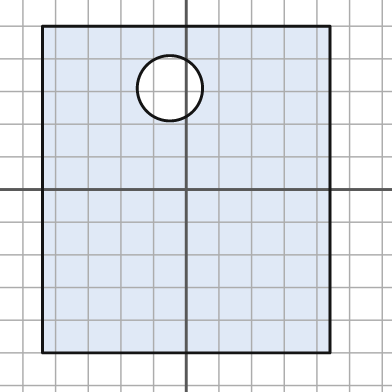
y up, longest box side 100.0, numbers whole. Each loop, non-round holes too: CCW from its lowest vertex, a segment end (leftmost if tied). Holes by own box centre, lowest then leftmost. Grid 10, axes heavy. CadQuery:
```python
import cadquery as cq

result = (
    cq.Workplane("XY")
    .moveTo(-44.0, -50.0)
    .lineTo(44.0, -50.0)
    .lineTo(44.0, 50.0)
    .lineTo(-44.0, 50.0)
    .close()
    .moveTo(-5.0, 31.0)
    .circle(10.0)
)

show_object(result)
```